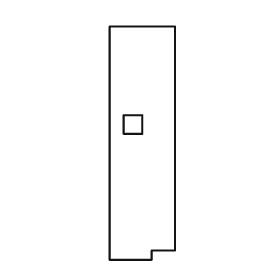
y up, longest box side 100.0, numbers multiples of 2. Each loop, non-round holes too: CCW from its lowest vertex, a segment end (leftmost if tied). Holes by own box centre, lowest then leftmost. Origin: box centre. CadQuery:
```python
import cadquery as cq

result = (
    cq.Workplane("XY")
    .moveTo(-14.0, -50.0)
    .lineTo(4.0, -50.0)
    .lineTo(4.0, -46.0)
    .lineTo(14.0, -46.0)
    .lineTo(14.0, 50.0)
    .lineTo(-14.0, 50.0)
    .close()
    .moveTo(-8.0, 4.0)
    .lineTo(0.0, 4.0)
    .lineTo(0.0, 12.0)
    .lineTo(-8.0, 12.0)
    .close()
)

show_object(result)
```